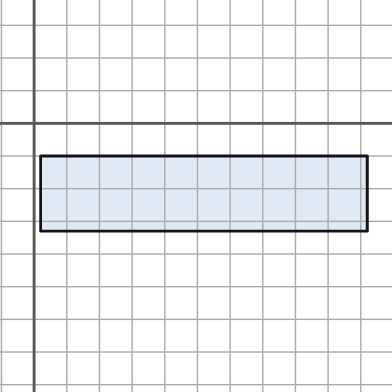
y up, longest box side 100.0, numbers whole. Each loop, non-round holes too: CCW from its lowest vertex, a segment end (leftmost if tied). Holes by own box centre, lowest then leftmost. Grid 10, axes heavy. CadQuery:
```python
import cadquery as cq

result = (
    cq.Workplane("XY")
    .moveTo(2.0, -33.0)
    .lineTo(102.0, -33.0)
    .lineTo(102.0, -10.0)
    .lineTo(2.0, -10.0)
    .close()
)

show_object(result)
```